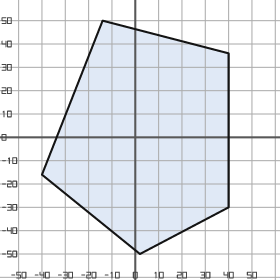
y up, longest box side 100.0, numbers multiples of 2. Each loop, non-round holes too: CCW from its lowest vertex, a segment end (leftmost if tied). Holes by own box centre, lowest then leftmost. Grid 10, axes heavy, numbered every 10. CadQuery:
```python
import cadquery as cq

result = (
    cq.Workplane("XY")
    .moveTo(2.0, -50.0)
    .lineTo(40.0, -30.0)
    .lineTo(40.0, 36.0)
    .lineTo(-14.0, 50.0)
    .lineTo(-40.0, -16.0)
    .close()
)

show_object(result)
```